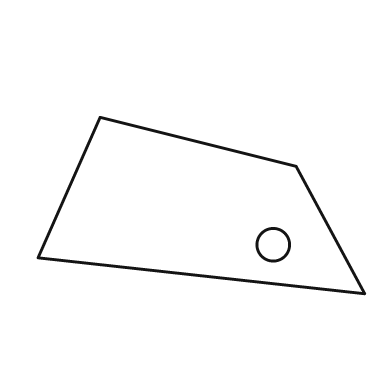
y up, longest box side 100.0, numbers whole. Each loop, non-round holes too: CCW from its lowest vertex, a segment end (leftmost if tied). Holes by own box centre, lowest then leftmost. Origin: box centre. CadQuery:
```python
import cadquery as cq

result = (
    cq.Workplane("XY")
    .moveTo(50.0, -27.0)
    .lineTo(29.0, 12.0)
    .lineTo(-31.0, 27.0)
    .lineTo(-50.0, -16.0)
    .close()
    .moveTo(22.0, -12.0)
    .circle(5.0)
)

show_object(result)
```